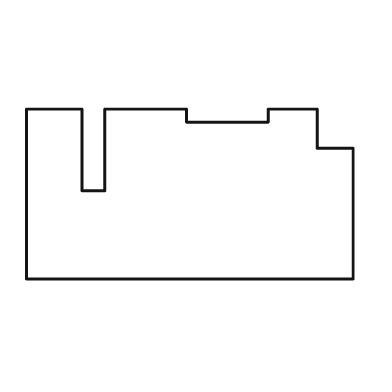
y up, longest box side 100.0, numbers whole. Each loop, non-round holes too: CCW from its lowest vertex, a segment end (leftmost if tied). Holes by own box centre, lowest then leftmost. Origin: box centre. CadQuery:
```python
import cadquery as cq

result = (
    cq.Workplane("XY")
    .moveTo(-50.0, -26.0)
    .lineTo(50.0, -26.0)
    .lineTo(50.0, 14.0)
    .lineTo(39.0, 14.0)
    .lineTo(39.0, 26.0)
    .lineTo(24.0, 26.0)
    .lineTo(24.0, 22.0)
    .lineTo(-1.0, 22.0)
    .lineTo(-1.0, 26.0)
    .lineTo(-26.0, 26.0)
    .lineTo(-26.0, 1.0)
    .lineTo(-33.0, 1.0)
    .lineTo(-33.0, 26.0)
    .lineTo(-50.0, 26.0)
    .close()
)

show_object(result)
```